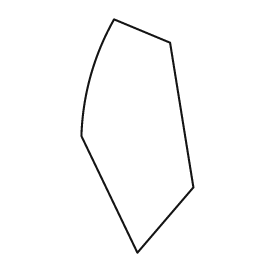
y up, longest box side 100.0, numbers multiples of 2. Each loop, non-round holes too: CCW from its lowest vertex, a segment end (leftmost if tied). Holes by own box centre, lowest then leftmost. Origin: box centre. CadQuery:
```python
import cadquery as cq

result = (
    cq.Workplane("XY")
    .moveTo(0.0, -50.0)
    .lineTo(24.0, -22.0)
    .lineTo(14.0, 40.0)
    .lineTo(-10.0, 50.0)
    .threePointArc((-20.0, 26.0), (-24.0, 0.0))
    .close()
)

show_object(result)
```